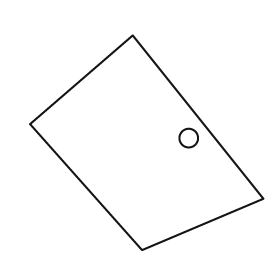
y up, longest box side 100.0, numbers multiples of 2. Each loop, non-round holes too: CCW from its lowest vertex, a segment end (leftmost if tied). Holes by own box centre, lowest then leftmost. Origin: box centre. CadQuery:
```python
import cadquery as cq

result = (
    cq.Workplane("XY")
    .moveTo(-2.0, -46.0)
    .lineTo(50.0, -24.0)
    .lineTo(-6.0, 46.0)
    .lineTo(-50.0, 8.0)
    .close()
    .moveTo(18.0, 2.0)
    .circle(4.0)
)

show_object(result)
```